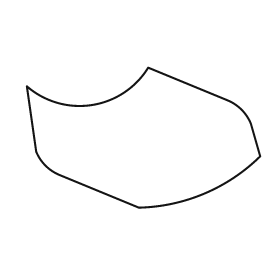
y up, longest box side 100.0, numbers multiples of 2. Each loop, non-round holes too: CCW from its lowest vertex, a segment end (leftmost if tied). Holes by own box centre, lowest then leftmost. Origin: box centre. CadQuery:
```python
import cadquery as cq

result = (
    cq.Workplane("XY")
    .moveTo(-2.0, -30.0)
    .threePointArc((26.0, -24.0), (50.0, -8.0))
    .lineTo(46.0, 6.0)
    .threePointArc((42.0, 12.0), (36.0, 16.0))
    .lineTo(2.0, 30.0)
    .threePointArc((-22.0, 14.0), (-50.0, 22.0))
    .lineTo(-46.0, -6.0)
    .threePointArc((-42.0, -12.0), (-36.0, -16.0))
    .close()
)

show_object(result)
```